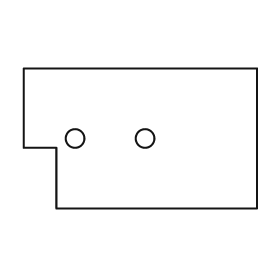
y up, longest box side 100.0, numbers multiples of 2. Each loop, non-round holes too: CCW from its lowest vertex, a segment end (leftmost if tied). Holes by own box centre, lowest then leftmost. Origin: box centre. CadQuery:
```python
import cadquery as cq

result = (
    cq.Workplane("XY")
    .moveTo(-36.0, -30.0)
    .lineTo(50.0, -30.0)
    .lineTo(50.0, 30.0)
    .lineTo(-50.0, 30.0)
    .lineTo(-50.0, -4.0)
    .lineTo(-36.0, -4.0)
    .close()
    .moveTo(-28.0, 0.0)
    .circle(4.0)
    .moveTo(2.0, 0.0)
    .circle(4.0)
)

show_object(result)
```